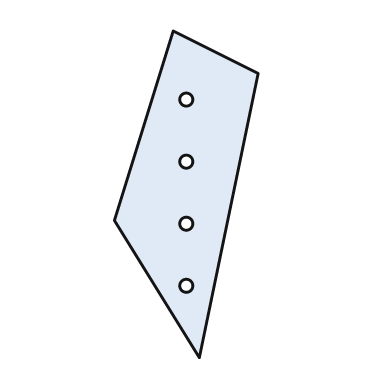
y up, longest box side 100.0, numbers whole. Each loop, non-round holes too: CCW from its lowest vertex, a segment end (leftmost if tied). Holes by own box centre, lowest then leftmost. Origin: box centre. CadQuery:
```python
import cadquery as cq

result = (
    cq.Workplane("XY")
    .moveTo(4.0, -50.0)
    .lineTo(22.0, 37.0)
    .lineTo(-4.0, 50.0)
    .lineTo(-22.0, -8.0)
    .close()
    .moveTo(0.0, -28.0)
    .circle(2.0)
    .moveTo(0.0, -9.0)
    .circle(2.0)
    .moveTo(0.0, 10.0)
    .circle(2.0)
    .moveTo(0.0, 29.0)
    .circle(2.0)
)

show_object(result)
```